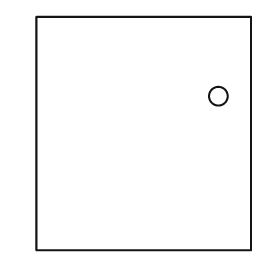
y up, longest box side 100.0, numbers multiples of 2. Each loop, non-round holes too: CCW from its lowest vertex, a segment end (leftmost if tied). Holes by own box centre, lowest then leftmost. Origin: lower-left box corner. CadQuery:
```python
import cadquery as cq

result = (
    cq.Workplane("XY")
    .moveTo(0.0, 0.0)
    .lineTo(92.0, 0.0)
    .lineTo(92.0, 100.0)
    .lineTo(0.0, 100.0)
    .close()
    .moveTo(78.0, 66.0)
    .circle(4.0)
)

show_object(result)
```